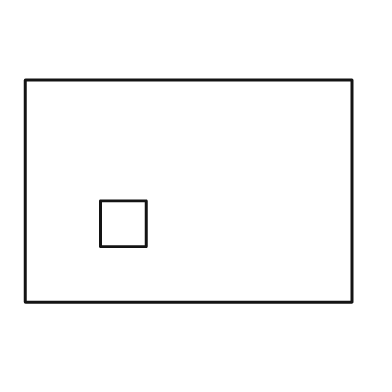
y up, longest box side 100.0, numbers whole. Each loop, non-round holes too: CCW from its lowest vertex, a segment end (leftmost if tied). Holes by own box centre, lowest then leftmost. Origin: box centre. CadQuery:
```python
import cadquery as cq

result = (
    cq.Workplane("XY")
    .moveTo(-50.0, -34.0)
    .lineTo(50.0, -34.0)
    .lineTo(50.0, 34.0)
    .lineTo(-50.0, 34.0)
    .close()
    .moveTo(-27.0, -17.0)
    .lineTo(-13.0, -17.0)
    .lineTo(-13.0, -3.0)
    .lineTo(-27.0, -3.0)
    .close()
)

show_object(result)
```